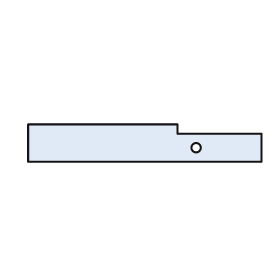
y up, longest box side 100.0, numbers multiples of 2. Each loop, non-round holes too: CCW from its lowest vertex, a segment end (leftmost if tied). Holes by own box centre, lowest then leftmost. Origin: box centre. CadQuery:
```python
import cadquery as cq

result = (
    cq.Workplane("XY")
    .moveTo(-50.0, -8.0)
    .lineTo(50.0, -8.0)
    .lineTo(50.0, 4.0)
    .lineTo(14.0, 4.0)
    .lineTo(14.0, 8.0)
    .lineTo(-50.0, 8.0)
    .close()
    .moveTo(22.0, -2.0)
    .circle(2.0)
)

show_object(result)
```